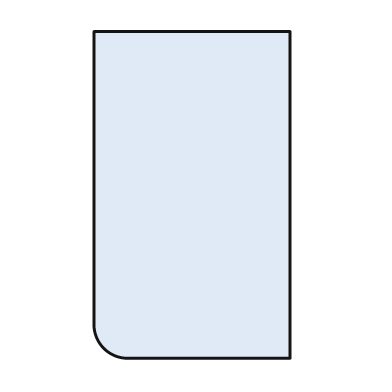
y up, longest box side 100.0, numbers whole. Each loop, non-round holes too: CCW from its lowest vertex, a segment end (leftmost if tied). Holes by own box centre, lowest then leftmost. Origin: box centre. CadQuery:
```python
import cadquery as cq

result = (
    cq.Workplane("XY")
    .moveTo(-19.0, -50.0)
    .lineTo(30.0, -50.0)
    .lineTo(30.0, 50.0)
    .lineTo(-30.0, 50.0)
    .lineTo(-30.0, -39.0)
    .threePointArc((-27.0, -47.0), (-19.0, -50.0))
    .close()
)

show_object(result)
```